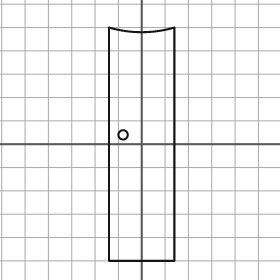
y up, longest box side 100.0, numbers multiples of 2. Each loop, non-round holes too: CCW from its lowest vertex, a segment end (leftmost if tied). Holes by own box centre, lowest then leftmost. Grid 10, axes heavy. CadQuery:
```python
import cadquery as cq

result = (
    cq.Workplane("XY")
    .moveTo(-14.0, -50.0)
    .lineTo(14.0, -50.0)
    .lineTo(14.0, 50.0)
    .threePointArc((0.0, 48.0), (-14.0, 50.0))
    .close()
    .moveTo(-8.0, 4.0)
    .circle(2.0)
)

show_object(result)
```